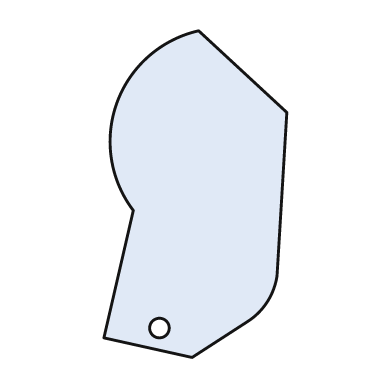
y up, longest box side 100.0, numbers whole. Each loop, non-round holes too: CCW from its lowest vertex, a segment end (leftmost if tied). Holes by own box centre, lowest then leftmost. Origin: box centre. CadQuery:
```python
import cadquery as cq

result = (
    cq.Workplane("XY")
    .moveTo(-1.0, -50.0)
    .lineTo(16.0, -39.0)
    .threePointArc((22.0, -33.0), (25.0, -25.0))
    .lineTo(28.0, 25.0)
    .lineTo(1.0, 50.0)
    .threePointArc((-24.0, 28.0), (-19.0, -5.0))
    .lineTo(-28.0, -44.0)
    .close()
    .moveTo(-11.0, -41.0)
    .circle(3.0)
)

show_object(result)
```